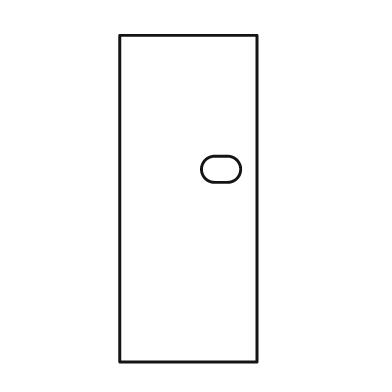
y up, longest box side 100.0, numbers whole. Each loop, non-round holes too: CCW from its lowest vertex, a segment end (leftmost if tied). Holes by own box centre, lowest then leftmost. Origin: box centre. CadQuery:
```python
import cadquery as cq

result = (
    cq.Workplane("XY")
    .moveTo(-21.0, -50.0)
    .lineTo(21.0, -50.0)
    .lineTo(21.0, 50.0)
    .lineTo(-21.0, 50.0)
    .close()
    .moveTo(8.0, 5.0)
    .lineTo(12.0, 5.0)
    .threePointArc((16.0, 9.0), (12.0, 13.0))
    .lineTo(8.0, 13.0)
    .threePointArc((4.0, 9.0), (8.0, 5.0))
    .close()
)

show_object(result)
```